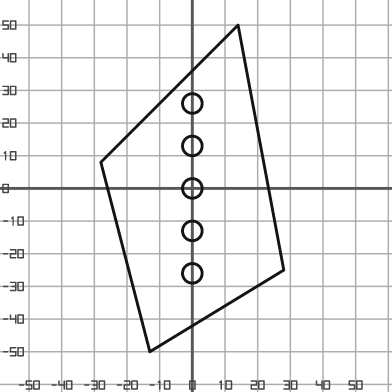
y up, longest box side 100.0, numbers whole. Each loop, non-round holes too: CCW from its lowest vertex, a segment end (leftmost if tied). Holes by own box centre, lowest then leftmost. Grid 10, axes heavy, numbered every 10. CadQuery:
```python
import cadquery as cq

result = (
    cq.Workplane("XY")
    .moveTo(-13.0, -50.0)
    .lineTo(28.0, -25.0)
    .lineTo(14.0, 50.0)
    .lineTo(-28.0, 8.0)
    .close()
    .moveTo(0.0, -26.0)
    .circle(3.0)
    .moveTo(0.0, -13.0)
    .circle(3.0)
    .moveTo(0.0, 0.0)
    .circle(3.0)
    .moveTo(0.0, 13.0)
    .circle(3.0)
    .moveTo(0.0, 26.0)
    .circle(3.0)
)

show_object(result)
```